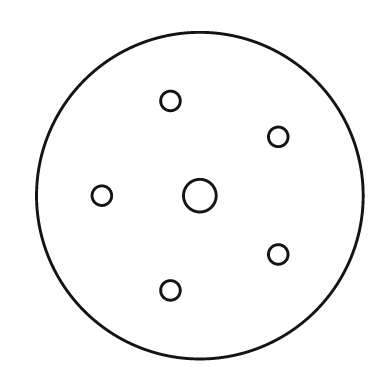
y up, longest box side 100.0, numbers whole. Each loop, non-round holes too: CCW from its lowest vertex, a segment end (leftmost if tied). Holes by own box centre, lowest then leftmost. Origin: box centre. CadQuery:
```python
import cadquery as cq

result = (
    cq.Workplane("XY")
    .moveTo(0.0, 0.0)
    .circle(50.0)
    .moveTo(-9.0, -29.0)
    .circle(3.0)
    .moveTo(24.0, -18.0)
    .circle(3.0)
    .moveTo(-30.0, 0.0)
    .circle(3.0)
    .moveTo(0.0, 0.0)
    .circle(5.0)
    .moveTo(24.0, 18.0)
    .circle(3.0)
    .moveTo(-9.0, 29.0)
    .circle(3.0)
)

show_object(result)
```